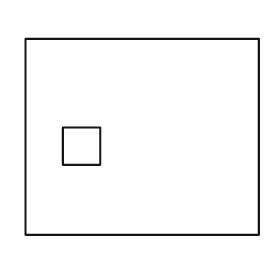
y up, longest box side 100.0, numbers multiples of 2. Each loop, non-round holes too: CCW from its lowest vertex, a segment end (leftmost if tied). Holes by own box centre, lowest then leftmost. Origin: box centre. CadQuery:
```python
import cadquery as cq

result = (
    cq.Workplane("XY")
    .moveTo(-50.0, -42.0)
    .lineTo(50.0, -42.0)
    .lineTo(50.0, 42.0)
    .lineTo(-50.0, 42.0)
    .close()
    .moveTo(-34.0, -12.0)
    .lineTo(-18.0, -12.0)
    .lineTo(-18.0, 4.0)
    .lineTo(-34.0, 4.0)
    .close()
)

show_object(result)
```